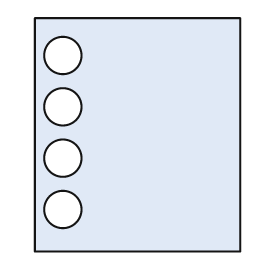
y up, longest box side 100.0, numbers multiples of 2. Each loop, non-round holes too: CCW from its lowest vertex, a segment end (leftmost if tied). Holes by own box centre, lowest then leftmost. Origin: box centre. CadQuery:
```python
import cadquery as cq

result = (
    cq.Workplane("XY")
    .moveTo(-44.0, -50.0)
    .lineTo(44.0, -50.0)
    .lineTo(44.0, 50.0)
    .lineTo(-44.0, 50.0)
    .close()
    .moveTo(-32.0, -32.0)
    .circle(8.0)
    .moveTo(-32.0, -10.0)
    .circle(8.0)
    .moveTo(-32.0, 12.0)
    .circle(8.0)
    .moveTo(-32.0, 34.0)
    .circle(8.0)
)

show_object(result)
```